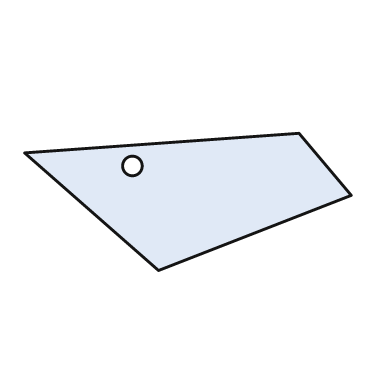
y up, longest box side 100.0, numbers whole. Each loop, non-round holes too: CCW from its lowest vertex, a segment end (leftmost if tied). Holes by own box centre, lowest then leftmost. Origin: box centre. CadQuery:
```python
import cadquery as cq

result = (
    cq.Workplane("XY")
    .moveTo(-9.0, -21.0)
    .lineTo(50.0, 2.0)
    .lineTo(34.0, 21.0)
    .lineTo(-50.0, 15.0)
    .close()
    .moveTo(-17.0, 11.0)
    .circle(3.0)
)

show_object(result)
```